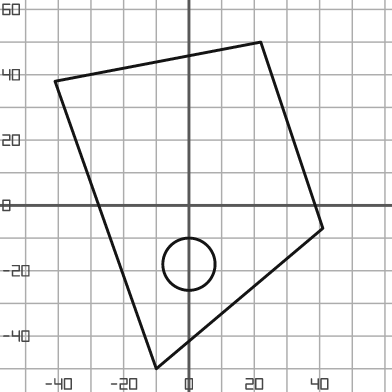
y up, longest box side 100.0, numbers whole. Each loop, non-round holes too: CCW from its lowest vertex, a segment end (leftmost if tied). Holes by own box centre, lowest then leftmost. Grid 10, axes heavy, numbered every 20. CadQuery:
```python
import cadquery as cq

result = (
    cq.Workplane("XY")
    .moveTo(-10.0, -50.0)
    .lineTo(41.0, -7.0)
    .lineTo(22.0, 50.0)
    .lineTo(-41.0, 38.0)
    .close()
    .moveTo(0.0, -18.0)
    .circle(8.0)
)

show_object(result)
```